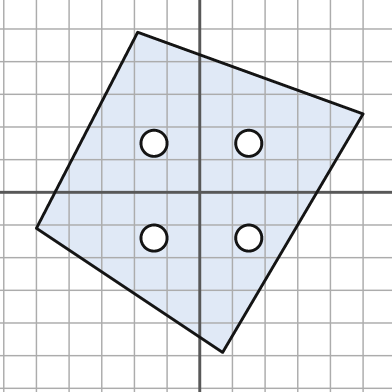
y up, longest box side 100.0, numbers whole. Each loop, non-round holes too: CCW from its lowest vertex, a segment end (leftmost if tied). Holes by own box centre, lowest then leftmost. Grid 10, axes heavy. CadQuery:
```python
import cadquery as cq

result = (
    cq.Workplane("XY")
    .moveTo(7.0, -49.0)
    .lineTo(50.0, 24.0)
    .lineTo(-19.0, 49.0)
    .lineTo(-50.0, -11.0)
    .close()
    .moveTo(-14.0, -14.0)
    .circle(4.0)
    .moveTo(15.0, -14.0)
    .circle(4.0)
    .moveTo(-14.0, 15.0)
    .circle(4.0)
    .moveTo(15.0, 15.0)
    .circle(4.0)
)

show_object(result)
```